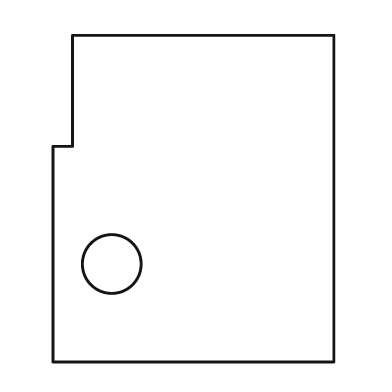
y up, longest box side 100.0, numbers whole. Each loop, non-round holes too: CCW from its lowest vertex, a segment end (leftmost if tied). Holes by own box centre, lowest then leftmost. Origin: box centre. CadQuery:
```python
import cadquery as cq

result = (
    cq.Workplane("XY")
    .moveTo(-43.0, -50.0)
    .lineTo(43.0, -50.0)
    .lineTo(43.0, 50.0)
    .lineTo(-37.0, 50.0)
    .lineTo(-37.0, 16.0)
    .lineTo(-43.0, 16.0)
    .close()
    .moveTo(-25.0, -20.0)
    .circle(9.0)
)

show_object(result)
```